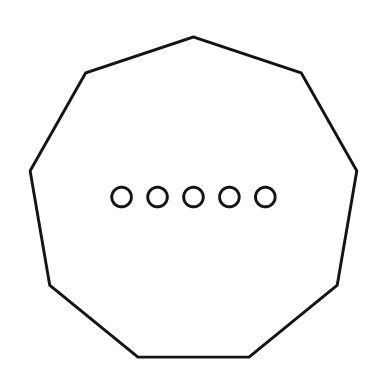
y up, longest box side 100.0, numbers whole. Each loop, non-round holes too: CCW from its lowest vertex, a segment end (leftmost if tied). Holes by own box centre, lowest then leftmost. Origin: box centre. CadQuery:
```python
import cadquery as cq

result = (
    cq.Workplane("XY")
    .moveTo(-17.0, -49.0)
    .lineTo(17.0, -49.0)
    .lineTo(44.0, -27.0)
    .lineTo(50.0, 8.0)
    .lineTo(33.0, 38.0)
    .lineTo(0.0, 49.0)
    .lineTo(-33.0, 38.0)
    .lineTo(-50.0, 8.0)
    .lineTo(-44.0, -27.0)
    .close()
    .moveTo(-22.0, 0.0)
    .circle(3.0)
    .moveTo(-11.0, 0.0)
    .circle(3.0)
    .moveTo(0.0, 0.0)
    .circle(3.0)
    .moveTo(11.0, 0.0)
    .circle(3.0)
    .moveTo(22.0, 0.0)
    .circle(3.0)
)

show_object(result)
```